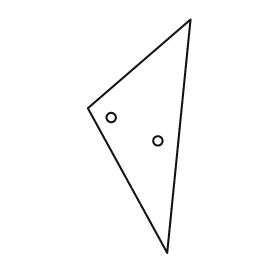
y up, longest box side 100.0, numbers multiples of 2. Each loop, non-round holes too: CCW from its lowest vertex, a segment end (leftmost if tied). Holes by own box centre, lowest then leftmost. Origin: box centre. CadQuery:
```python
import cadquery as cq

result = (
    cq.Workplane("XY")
    .moveTo(12.0, -50.0)
    .lineTo(22.0, 50.0)
    .lineTo(-22.0, 12.0)
    .close()
    .moveTo(8.0, -2.0)
    .circle(2.0)
    .moveTo(-12.0, 8.0)
    .circle(2.0)
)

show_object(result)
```